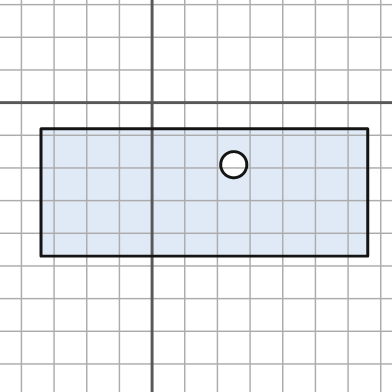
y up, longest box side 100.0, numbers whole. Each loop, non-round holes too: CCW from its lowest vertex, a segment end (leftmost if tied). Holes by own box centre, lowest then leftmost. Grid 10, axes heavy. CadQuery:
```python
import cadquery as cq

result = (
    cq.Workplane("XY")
    .moveTo(-34.0, -47.0)
    .lineTo(66.0, -47.0)
    .lineTo(66.0, -8.0)
    .lineTo(-34.0, -8.0)
    .close()
    .moveTo(25.0, -19.0)
    .circle(4.0)
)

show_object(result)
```